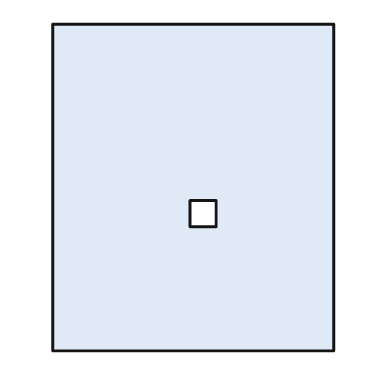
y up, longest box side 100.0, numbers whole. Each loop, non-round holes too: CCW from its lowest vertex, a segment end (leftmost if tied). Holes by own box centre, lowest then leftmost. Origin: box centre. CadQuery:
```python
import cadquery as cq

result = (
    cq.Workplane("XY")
    .moveTo(-43.0, -50.0)
    .lineTo(43.0, -50.0)
    .lineTo(43.0, 50.0)
    .lineTo(-43.0, 50.0)
    .close()
    .moveTo(-1.0, -12.0)
    .lineTo(7.0, -12.0)
    .lineTo(7.0, -4.0)
    .lineTo(-1.0, -4.0)
    .close()
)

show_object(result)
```